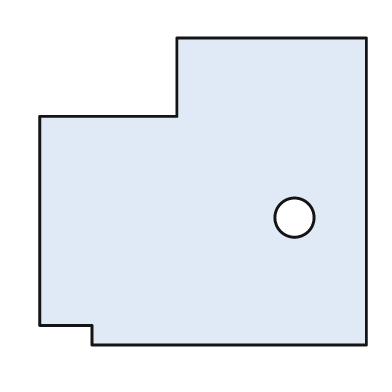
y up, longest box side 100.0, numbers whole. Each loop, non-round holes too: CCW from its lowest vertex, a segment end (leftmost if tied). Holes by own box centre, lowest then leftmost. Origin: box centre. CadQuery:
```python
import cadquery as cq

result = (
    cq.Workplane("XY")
    .moveTo(-34.0, -47.0)
    .lineTo(50.0, -47.0)
    .lineTo(50.0, 47.0)
    .lineTo(-8.0, 47.0)
    .lineTo(-8.0, 23.0)
    .lineTo(-50.0, 23.0)
    .lineTo(-50.0, -41.0)
    .lineTo(-34.0, -41.0)
    .close()
    .moveTo(28.0, -8.0)
    .circle(6.0)
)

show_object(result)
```